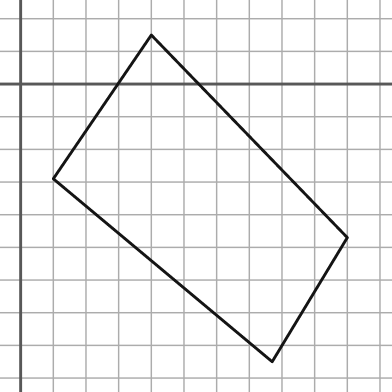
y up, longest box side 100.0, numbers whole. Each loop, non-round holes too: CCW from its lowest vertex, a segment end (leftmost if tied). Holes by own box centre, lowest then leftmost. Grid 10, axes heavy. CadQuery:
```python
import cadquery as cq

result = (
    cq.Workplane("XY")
    .moveTo(77.0, -85.0)
    .lineTo(100.0, -47.0)
    .lineTo(40.0, 15.0)
    .lineTo(10.0, -29.0)
    .close()
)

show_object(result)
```